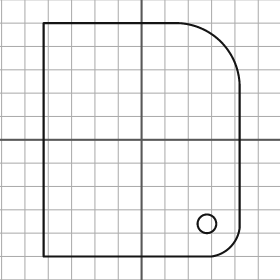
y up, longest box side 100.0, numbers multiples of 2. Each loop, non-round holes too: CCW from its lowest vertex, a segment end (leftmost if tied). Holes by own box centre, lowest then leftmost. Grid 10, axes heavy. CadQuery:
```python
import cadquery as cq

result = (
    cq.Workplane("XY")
    .moveTo(-42.0, -50.0)
    .lineTo(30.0, -50.0)
    .threePointArc((38.0, -46.0), (42.0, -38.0))
    .lineTo(42.0, 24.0)
    .threePointArc((34.0, 42.0), (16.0, 50.0))
    .lineTo(-42.0, 50.0)
    .close()
    .moveTo(28.0, -36.0)
    .circle(4.0)
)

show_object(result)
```